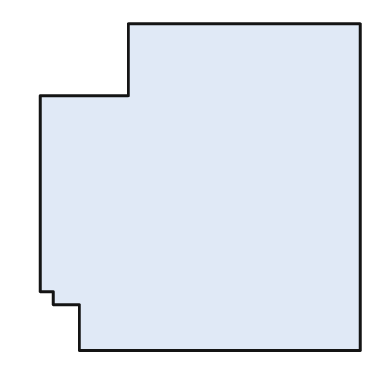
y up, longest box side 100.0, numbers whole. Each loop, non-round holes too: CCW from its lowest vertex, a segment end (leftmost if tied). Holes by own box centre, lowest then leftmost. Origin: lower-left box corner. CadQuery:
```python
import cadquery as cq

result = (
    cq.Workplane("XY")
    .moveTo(12.0, 0.0)
    .lineTo(98.0, 0.0)
    .lineTo(98.0, 100.0)
    .lineTo(27.0, 100.0)
    .lineTo(27.0, 78.0)
    .lineTo(0.0, 78.0)
    .lineTo(0.0, 18.0)
    .lineTo(4.0, 18.0)
    .lineTo(4.0, 14.0)
    .lineTo(12.0, 14.0)
    .close()
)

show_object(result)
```